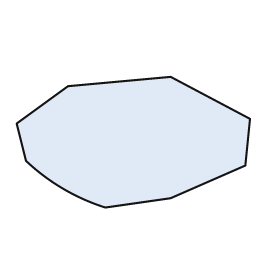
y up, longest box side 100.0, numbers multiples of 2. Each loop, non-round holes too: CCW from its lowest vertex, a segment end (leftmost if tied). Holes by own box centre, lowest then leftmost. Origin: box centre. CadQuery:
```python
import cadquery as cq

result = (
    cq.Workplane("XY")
    .moveTo(-12.0, -28.0)
    .lineTo(16.0, -24.0)
    .lineTo(48.0, -10.0)
    .lineTo(50.0, 10.0)
    .lineTo(16.0, 28.0)
    .lineTo(-28.0, 24.0)
    .lineTo(-50.0, 8.0)
    .lineTo(-46.0, -8.0)
    .threePointArc((-30.0, -20.0), (-12.0, -28.0))
    .close()
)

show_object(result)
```